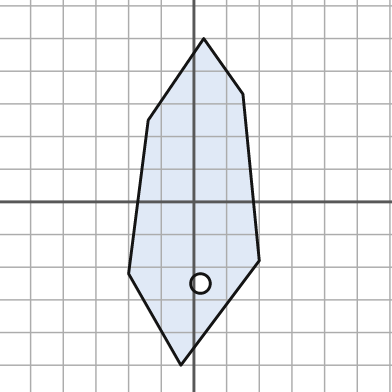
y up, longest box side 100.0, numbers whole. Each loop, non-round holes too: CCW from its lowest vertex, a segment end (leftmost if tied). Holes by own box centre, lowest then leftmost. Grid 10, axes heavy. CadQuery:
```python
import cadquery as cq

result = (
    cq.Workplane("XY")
    .moveTo(-4.0, -50.0)
    .lineTo(20.0, -18.0)
    .lineTo(15.0, 33.0)
    .lineTo(3.0, 50.0)
    .lineTo(-14.0, 25.0)
    .lineTo(-20.0, -22.0)
    .close()
    .moveTo(2.0, -25.0)
    .circle(3.0)
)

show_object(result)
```